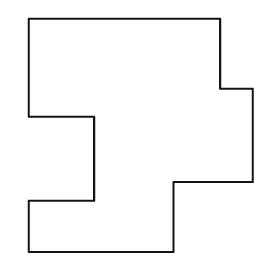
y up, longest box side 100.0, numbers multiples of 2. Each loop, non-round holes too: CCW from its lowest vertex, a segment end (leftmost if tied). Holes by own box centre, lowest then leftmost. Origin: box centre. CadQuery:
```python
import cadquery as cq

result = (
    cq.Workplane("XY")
    .moveTo(-48.0, -50.0)
    .lineTo(14.0, -50.0)
    .lineTo(14.0, -20.0)
    .lineTo(48.0, -20.0)
    .lineTo(48.0, 20.0)
    .lineTo(34.0, 20.0)
    .lineTo(34.0, 50.0)
    .lineTo(-48.0, 50.0)
    .lineTo(-48.0, 8.0)
    .lineTo(-20.0, 8.0)
    .lineTo(-20.0, -28.0)
    .lineTo(-48.0, -28.0)
    .close()
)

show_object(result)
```